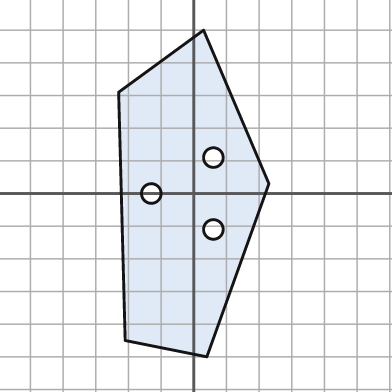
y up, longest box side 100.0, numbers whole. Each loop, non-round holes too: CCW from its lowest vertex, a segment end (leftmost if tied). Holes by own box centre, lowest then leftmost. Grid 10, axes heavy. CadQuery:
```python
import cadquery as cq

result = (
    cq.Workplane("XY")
    .moveTo(4.0, -50.0)
    .lineTo(23.0, 3.0)
    .lineTo(3.0, 50.0)
    .lineTo(-23.0, 31.0)
    .lineTo(-21.0, -45.0)
    .close()
    .moveTo(6.0, -11.0)
    .circle(3.0)
    .moveTo(-13.0, 0.0)
    .circle(3.0)
    .moveTo(6.0, 11.0)
    .circle(3.0)
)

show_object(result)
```